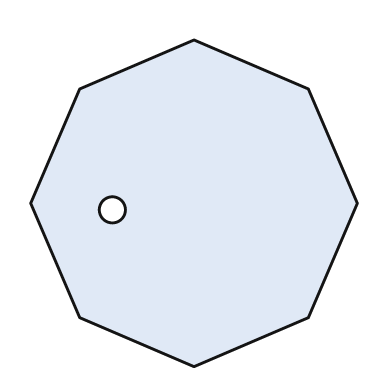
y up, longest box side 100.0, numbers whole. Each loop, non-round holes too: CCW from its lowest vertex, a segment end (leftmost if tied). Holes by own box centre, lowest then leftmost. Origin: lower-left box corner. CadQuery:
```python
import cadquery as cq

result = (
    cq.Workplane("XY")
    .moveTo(50.0, 0.0)
    .lineTo(85.0, 15.0)
    .lineTo(100.0, 50.0)
    .lineTo(85.0, 85.0)
    .lineTo(50.0, 100.0)
    .lineTo(15.0, 85.0)
    .lineTo(0.0, 50.0)
    .lineTo(15.0, 15.0)
    .close()
    .moveTo(25.0, 48.0)
    .circle(4.0)
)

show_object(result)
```